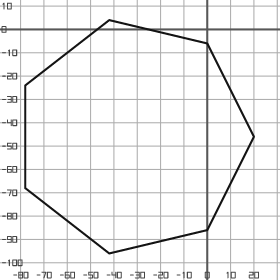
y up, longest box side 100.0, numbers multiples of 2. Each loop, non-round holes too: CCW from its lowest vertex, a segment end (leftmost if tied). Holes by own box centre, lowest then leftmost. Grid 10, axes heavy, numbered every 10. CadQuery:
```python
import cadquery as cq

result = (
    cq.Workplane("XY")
    .moveTo(-42.0, -96.0)
    .lineTo(0.0, -86.0)
    .lineTo(20.0, -46.0)
    .lineTo(0.0, -6.0)
    .lineTo(-42.0, 4.0)
    .lineTo(-78.0, -24.0)
    .lineTo(-78.0, -68.0)
    .close()
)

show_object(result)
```